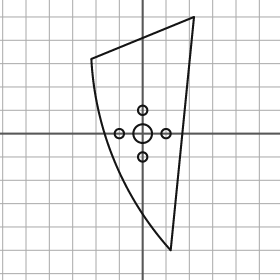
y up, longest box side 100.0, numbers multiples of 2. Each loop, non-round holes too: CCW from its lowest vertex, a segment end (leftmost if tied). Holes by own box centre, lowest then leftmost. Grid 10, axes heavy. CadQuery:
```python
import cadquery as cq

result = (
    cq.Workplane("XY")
    .moveTo(12.0, -50.0)
    .lineTo(22.0, 50.0)
    .lineTo(-22.0, 32.0)
    .threePointArc((-12.0, -12.0), (12.0, -50.0))
    .close()
    .moveTo(0.0, -10.0)
    .circle(2.0)
    .moveTo(-10.0, 0.0)
    .circle(2.0)
    .moveTo(0.0, 0.0)
    .circle(4.0)
    .moveTo(10.0, 0.0)
    .circle(2.0)
    .moveTo(0.0, 10.0)
    .circle(2.0)
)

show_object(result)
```